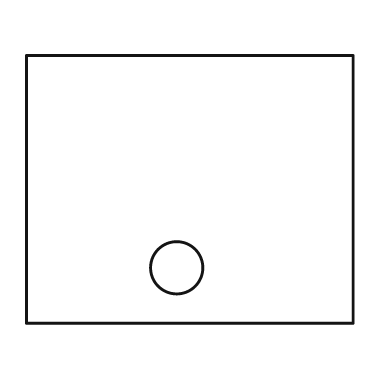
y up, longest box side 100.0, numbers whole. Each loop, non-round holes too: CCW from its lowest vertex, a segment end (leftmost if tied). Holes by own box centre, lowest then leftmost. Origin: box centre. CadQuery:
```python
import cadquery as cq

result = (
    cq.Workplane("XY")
    .moveTo(-50.0, -41.0)
    .lineTo(50.0, -41.0)
    .lineTo(50.0, 41.0)
    .lineTo(-50.0, 41.0)
    .close()
    .moveTo(-4.0, -24.0)
    .circle(8.0)
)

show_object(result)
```